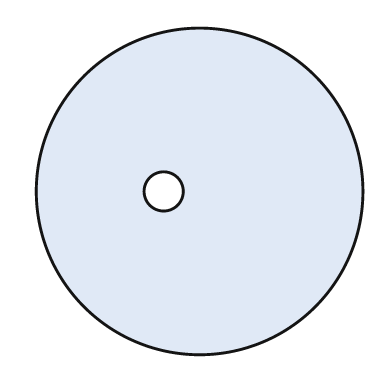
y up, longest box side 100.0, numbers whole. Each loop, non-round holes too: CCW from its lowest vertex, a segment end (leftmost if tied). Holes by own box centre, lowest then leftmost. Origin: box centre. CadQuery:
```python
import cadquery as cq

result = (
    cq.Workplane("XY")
    .moveTo(0.0, 0.0)
    .circle(50.0)
    .moveTo(-11.0, 0.0)
    .circle(6.0)
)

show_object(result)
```